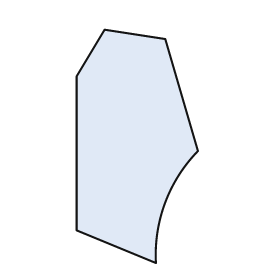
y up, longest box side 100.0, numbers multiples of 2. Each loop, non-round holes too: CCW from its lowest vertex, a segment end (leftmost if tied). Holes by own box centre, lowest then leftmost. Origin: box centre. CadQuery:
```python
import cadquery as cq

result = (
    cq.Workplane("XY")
    .moveTo(8.0, -50.0)
    .threePointArc((12.0, -24.0), (26.0, -2.0))
    .lineTo(12.0, 46.0)
    .lineTo(-14.0, 50.0)
    .lineTo(-26.0, 30.0)
    .lineTo(-26.0, -36.0)
    .close()
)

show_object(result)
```